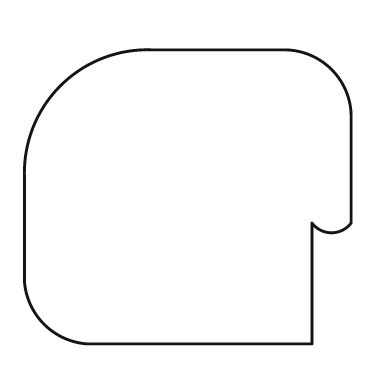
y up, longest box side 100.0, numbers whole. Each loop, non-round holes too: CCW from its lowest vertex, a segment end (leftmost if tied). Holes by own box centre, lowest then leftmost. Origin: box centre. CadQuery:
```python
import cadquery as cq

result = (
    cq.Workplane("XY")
    .moveTo(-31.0, -45.0)
    .lineTo(38.0, -45.0)
    .lineTo(38.0, -8.0)
    .threePointArc((44.0, -11.0), (50.0, -8.0))
    .lineTo(50.0, 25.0)
    .threePointArc((44.0, 39.0), (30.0, 45.0))
    .lineTo(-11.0, 45.0)
    .threePointArc((-39.0, 34.0), (-50.0, 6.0))
    .lineTo(-50.0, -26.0)
    .threePointArc((-44.0, -39.0), (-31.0, -45.0))
    .close()
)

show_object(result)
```